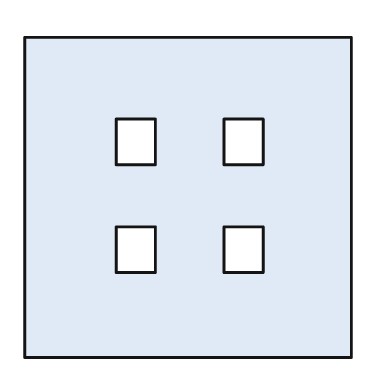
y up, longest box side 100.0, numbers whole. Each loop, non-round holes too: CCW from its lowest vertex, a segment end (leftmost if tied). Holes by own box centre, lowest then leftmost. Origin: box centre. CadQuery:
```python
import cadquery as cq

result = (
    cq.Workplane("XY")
    .moveTo(-50.0, -49.0)
    .lineTo(50.0, -49.0)
    .lineTo(50.0, 49.0)
    .lineTo(-50.0, 49.0)
    .close()
    .moveTo(-22.0, -23.0)
    .lineTo(-10.0, -23.0)
    .lineTo(-10.0, -9.0)
    .lineTo(-22.0, -9.0)
    .close()
    .moveTo(11.0, -23.0)
    .lineTo(23.0, -23.0)
    .lineTo(23.0, -9.0)
    .lineTo(11.0, -9.0)
    .close()
    .moveTo(-22.0, 10.0)
    .lineTo(-10.0, 10.0)
    .lineTo(-10.0, 24.0)
    .lineTo(-22.0, 24.0)
    .close()
    .moveTo(11.0, 10.0)
    .lineTo(23.0, 10.0)
    .lineTo(23.0, 24.0)
    .lineTo(11.0, 24.0)
    .close()
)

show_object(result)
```